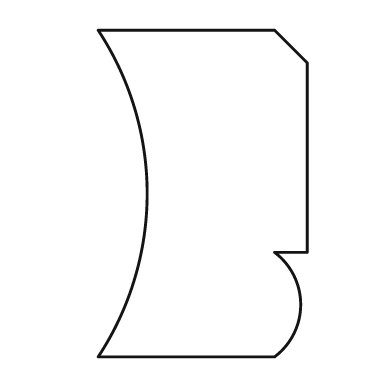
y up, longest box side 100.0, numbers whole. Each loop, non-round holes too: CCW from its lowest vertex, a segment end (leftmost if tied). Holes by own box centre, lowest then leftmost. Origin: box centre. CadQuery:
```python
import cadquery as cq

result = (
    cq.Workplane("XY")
    .moveTo(-32.0, -50.0)
    .lineTo(22.0, -50.0)
    .threePointArc((30.0, -34.0), (22.0, -18.0))
    .lineTo(32.0, -18.0)
    .lineTo(32.0, 40.0)
    .lineTo(22.0, 50.0)
    .lineTo(-32.0, 50.0)
    .threePointArc((-17.0, 0.0), (-32.0, -50.0))
    .close()
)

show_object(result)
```